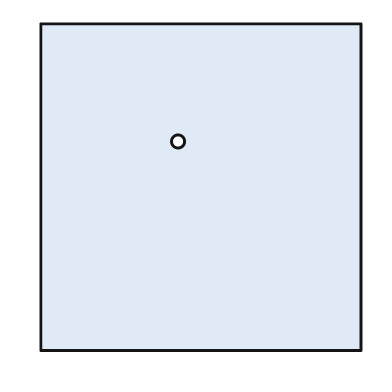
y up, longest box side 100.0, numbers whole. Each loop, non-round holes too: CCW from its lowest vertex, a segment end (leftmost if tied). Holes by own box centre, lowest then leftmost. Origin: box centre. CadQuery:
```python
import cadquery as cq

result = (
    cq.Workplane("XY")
    .moveTo(-49.0, -50.0)
    .lineTo(49.0, -50.0)
    .lineTo(49.0, 50.0)
    .lineTo(-49.0, 50.0)
    .close()
    .moveTo(-7.0, 14.0)
    .circle(2.0)
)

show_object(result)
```